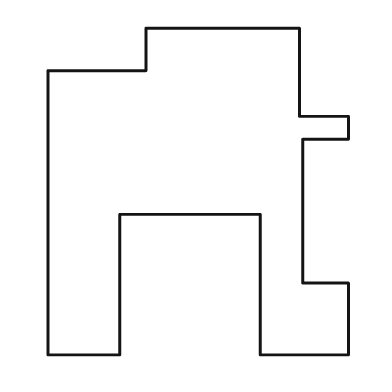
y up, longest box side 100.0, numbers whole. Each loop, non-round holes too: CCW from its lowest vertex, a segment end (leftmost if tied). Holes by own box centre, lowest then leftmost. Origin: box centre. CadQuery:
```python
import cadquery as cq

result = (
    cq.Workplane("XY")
    .moveTo(-46.0, -50.0)
    .lineTo(-24.0, -50.0)
    .lineTo(-24.0, -7.0)
    .lineTo(19.0, -7.0)
    .lineTo(19.0, -50.0)
    .lineTo(46.0, -50.0)
    .lineTo(46.0, -28.0)
    .lineTo(32.0, -28.0)
    .lineTo(32.0, 16.0)
    .lineTo(46.0, 16.0)
    .lineTo(46.0, 23.0)
    .lineTo(31.0, 23.0)
    .lineTo(31.0, 50.0)
    .lineTo(-16.0, 50.0)
    .lineTo(-16.0, 37.0)
    .lineTo(-46.0, 37.0)
    .close()
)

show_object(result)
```